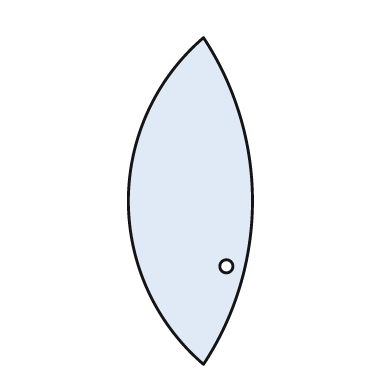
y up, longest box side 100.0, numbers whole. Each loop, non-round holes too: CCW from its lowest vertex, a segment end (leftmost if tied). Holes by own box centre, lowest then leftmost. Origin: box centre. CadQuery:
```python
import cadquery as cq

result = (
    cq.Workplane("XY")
    .moveTo(4.0, -50.0)
    .threePointArc((19.0, 0.0), (4.0, 50.0))
    .threePointArc((-19.0, 0.0), (4.0, -50.0))
    .close()
    .moveTo(11.0, -20.0)
    .circle(2.0)
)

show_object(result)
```